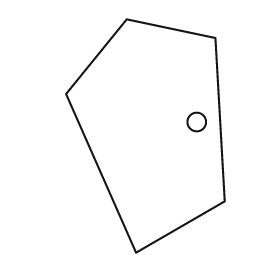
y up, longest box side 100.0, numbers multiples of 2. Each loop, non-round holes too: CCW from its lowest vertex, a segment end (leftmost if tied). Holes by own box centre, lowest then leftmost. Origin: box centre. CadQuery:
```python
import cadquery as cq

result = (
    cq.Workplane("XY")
    .moveTo(-4.0, -50.0)
    .lineTo(34.0, -28.0)
    .lineTo(30.0, 42.0)
    .lineTo(-8.0, 50.0)
    .lineTo(-34.0, 18.0)
    .close()
    .moveTo(22.0, 6.0)
    .circle(4.0)
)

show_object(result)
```